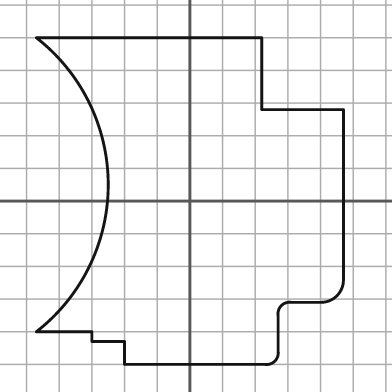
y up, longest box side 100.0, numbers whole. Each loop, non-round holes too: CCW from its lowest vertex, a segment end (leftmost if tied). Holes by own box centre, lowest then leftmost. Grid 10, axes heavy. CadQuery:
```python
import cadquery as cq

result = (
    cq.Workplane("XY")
    .moveTo(-20.0, -50.0)
    .lineTo(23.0, -50.0)
    .threePointArc((26.0, -49.0), (27.0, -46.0))
    .lineTo(27.0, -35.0)
    .threePointArc((28.0, -32.0), (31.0, -31.0))
    .lineTo(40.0, -31.0)
    .threePointArc((45.0, -29.0), (47.0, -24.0))
    .lineTo(47.0, 28.0)
    .lineTo(22.0, 28.0)
    .lineTo(22.0, 50.0)
    .lineTo(-47.0, 50.0)
    .threePointArc((-25.0, 5.0), (-47.0, -40.0))
    .lineTo(-30.0, -40.0)
    .lineTo(-30.0, -43.0)
    .lineTo(-20.0, -43.0)
    .close()
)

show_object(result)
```